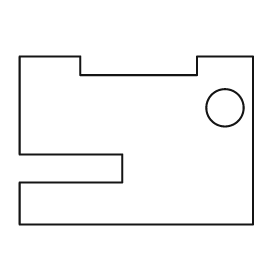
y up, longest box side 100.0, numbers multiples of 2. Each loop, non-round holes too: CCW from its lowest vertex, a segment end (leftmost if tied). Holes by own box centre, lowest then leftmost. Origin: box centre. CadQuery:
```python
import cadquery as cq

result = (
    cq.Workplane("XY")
    .moveTo(-50.0, -36.0)
    .lineTo(50.0, -36.0)
    .lineTo(50.0, 36.0)
    .lineTo(26.0, 36.0)
    .lineTo(26.0, 28.0)
    .lineTo(-24.0, 28.0)
    .lineTo(-24.0, 36.0)
    .lineTo(-50.0, 36.0)
    .lineTo(-50.0, -6.0)
    .lineTo(-6.0, -6.0)
    .lineTo(-6.0, -18.0)
    .lineTo(-50.0, -18.0)
    .close()
    .moveTo(38.0, 14.0)
    .circle(8.0)
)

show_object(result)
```